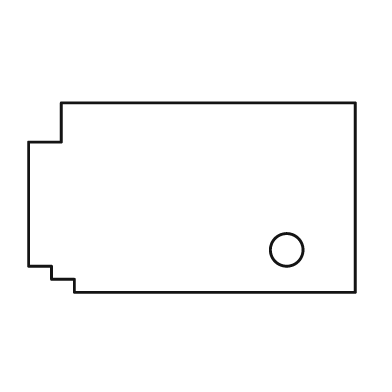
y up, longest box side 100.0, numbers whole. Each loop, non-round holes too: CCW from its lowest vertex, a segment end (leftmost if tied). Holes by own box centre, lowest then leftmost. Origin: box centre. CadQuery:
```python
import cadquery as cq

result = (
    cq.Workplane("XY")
    .moveTo(-36.0, -29.0)
    .lineTo(50.0, -29.0)
    .lineTo(50.0, 29.0)
    .lineTo(-40.0, 29.0)
    .lineTo(-40.0, 17.0)
    .lineTo(-50.0, 17.0)
    .lineTo(-50.0, -21.0)
    .lineTo(-43.0, -21.0)
    .lineTo(-43.0, -25.0)
    .lineTo(-36.0, -25.0)
    .close()
    .moveTo(29.0, -16.0)
    .circle(5.0)
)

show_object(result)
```